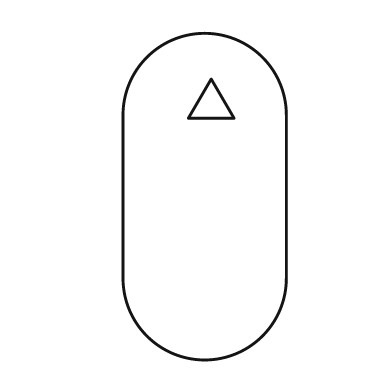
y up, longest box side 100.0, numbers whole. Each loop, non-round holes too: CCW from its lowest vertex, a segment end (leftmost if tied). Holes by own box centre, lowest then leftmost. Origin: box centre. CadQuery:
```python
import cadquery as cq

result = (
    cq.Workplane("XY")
    .moveTo(-25.0, -25.0)
    .threePointArc((0.0, -50.0), (25.0, -25.0))
    .lineTo(25.0, 25.0)
    .threePointArc((0.0, 50.0), (-25.0, 25.0))
    .close()
    .moveTo(-5.0, 24.0)
    .lineTo(9.0, 24.0)
    .lineTo(2.0, 36.0)
    .close()
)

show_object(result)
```